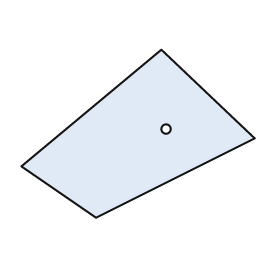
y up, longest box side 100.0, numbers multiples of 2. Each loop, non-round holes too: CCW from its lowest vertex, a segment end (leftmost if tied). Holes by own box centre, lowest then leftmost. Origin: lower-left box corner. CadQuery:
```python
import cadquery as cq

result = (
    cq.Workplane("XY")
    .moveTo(32.0, 0.0)
    .lineTo(100.0, 34.0)
    .lineTo(60.0, 72.0)
    .lineTo(0.0, 22.0)
    .close()
    .moveTo(62.0, 38.0)
    .circle(2.0)
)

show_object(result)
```